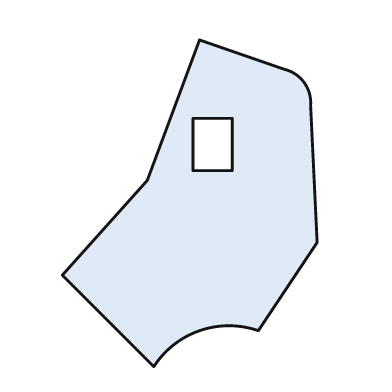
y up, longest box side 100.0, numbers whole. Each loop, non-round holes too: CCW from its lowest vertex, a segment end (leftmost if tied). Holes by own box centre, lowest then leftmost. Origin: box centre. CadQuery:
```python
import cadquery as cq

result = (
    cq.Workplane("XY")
    .moveTo(-11.0, -50.0)
    .threePointArc((3.0, -39.0), (21.0, -39.0))
    .lineTo(39.0, -12.0)
    .lineTo(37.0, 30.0)
    .threePointArc((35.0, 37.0), (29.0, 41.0))
    .lineTo(3.0, 50.0)
    .lineTo(-13.0, 7.0)
    .lineTo(-39.0, -22.0)
    .close()
    .moveTo(1.0, 10.0)
    .lineTo(13.0, 10.0)
    .lineTo(13.0, 26.0)
    .lineTo(1.0, 26.0)
    .close()
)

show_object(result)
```